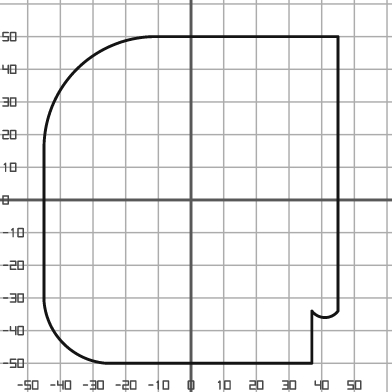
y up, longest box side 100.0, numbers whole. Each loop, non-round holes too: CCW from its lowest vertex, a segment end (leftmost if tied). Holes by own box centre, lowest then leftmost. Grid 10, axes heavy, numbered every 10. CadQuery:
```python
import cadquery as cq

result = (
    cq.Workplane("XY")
    .moveTo(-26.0, -50.0)
    .lineTo(37.0, -50.0)
    .lineTo(37.0, -34.0)
    .threePointArc((41.0, -36.0), (45.0, -34.0))
    .lineTo(45.0, 50.0)
    .lineTo(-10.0, 50.0)
    .threePointArc((-35.0, 40.0), (-45.0, 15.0))
    .lineTo(-45.0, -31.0)
    .threePointArc((-39.0, -44.0), (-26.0, -50.0))
    .close()
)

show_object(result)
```